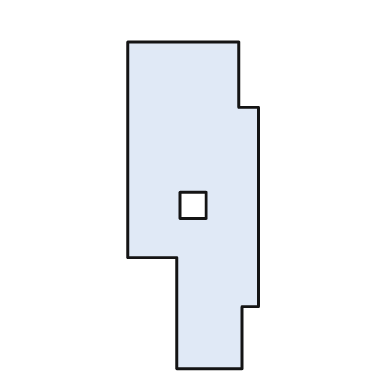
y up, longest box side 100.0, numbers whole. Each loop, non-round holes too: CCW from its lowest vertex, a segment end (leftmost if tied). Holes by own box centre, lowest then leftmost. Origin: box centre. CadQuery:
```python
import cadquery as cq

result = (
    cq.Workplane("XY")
    .moveTo(-5.0, -50.0)
    .lineTo(15.0, -50.0)
    .lineTo(15.0, -31.0)
    .lineTo(20.0, -31.0)
    .lineTo(20.0, 30.0)
    .lineTo(14.0, 30.0)
    .lineTo(14.0, 50.0)
    .lineTo(-20.0, 50.0)
    .lineTo(-20.0, -16.0)
    .lineTo(-5.0, -16.0)
    .close()
    .moveTo(-4.0, -4.0)
    .lineTo(4.0, -4.0)
    .lineTo(4.0, 4.0)
    .lineTo(-4.0, 4.0)
    .close()
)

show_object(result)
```